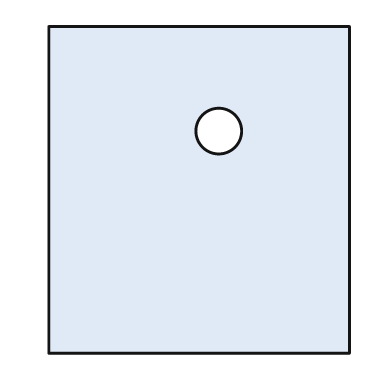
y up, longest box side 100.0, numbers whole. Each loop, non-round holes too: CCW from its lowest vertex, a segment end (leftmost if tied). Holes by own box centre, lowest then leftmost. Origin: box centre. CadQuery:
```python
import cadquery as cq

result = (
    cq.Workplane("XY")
    .moveTo(-46.0, -50.0)
    .lineTo(46.0, -50.0)
    .lineTo(46.0, 50.0)
    .lineTo(-46.0, 50.0)
    .close()
    .moveTo(6.0, 18.0)
    .circle(7.0)
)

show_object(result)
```